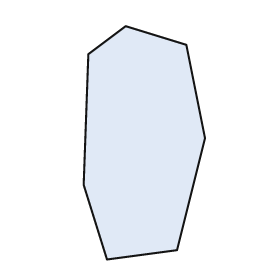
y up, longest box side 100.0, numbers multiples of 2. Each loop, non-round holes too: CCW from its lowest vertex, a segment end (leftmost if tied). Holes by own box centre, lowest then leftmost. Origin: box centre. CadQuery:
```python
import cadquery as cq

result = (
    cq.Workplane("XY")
    .moveTo(-16.0, -50.0)
    .lineTo(14.0, -46.0)
    .lineTo(26.0, 2.0)
    .lineTo(18.0, 42.0)
    .lineTo(-8.0, 50.0)
    .lineTo(-24.0, 38.0)
    .lineTo(-26.0, -18.0)
    .close()
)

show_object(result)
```